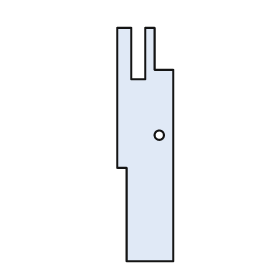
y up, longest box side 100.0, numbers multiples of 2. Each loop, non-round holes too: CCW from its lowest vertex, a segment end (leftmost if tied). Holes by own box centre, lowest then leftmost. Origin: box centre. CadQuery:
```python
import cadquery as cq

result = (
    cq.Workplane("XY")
    .moveTo(-8.0, -50.0)
    .lineTo(12.0, -50.0)
    .lineTo(12.0, 32.0)
    .lineTo(4.0, 32.0)
    .lineTo(4.0, 50.0)
    .lineTo(0.0, 50.0)
    .lineTo(0.0, 28.0)
    .lineTo(-6.0, 28.0)
    .lineTo(-6.0, 50.0)
    .lineTo(-12.0, 50.0)
    .lineTo(-12.0, -10.0)
    .lineTo(-8.0, -10.0)
    .close()
    .moveTo(6.0, 4.0)
    .circle(2.0)
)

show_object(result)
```